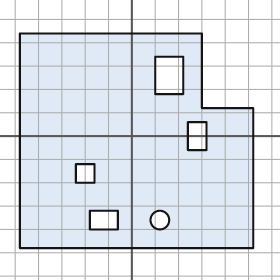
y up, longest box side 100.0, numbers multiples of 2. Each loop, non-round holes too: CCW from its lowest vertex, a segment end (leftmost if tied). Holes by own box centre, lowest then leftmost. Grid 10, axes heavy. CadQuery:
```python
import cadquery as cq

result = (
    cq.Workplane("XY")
    .moveTo(-48.0, -48.0)
    .lineTo(52.0, -48.0)
    .lineTo(52.0, 12.0)
    .lineTo(30.0, 12.0)
    .lineTo(30.0, 44.0)
    .lineTo(-48.0, 44.0)
    .close()
    .moveTo(-18.0, -40.0)
    .lineTo(-6.0, -40.0)
    .lineTo(-6.0, -32.0)
    .lineTo(-18.0, -32.0)
    .close()
    .moveTo(12.0, -36.0)
    .circle(4.0)
    .moveTo(-24.0, -20.0)
    .lineTo(-16.0, -20.0)
    .lineTo(-16.0, -12.0)
    .lineTo(-24.0, -12.0)
    .close()
    .moveTo(24.0, -6.0)
    .lineTo(32.0, -6.0)
    .lineTo(32.0, 6.0)
    .lineTo(24.0, 6.0)
    .close()
    .moveTo(10.0, 18.0)
    .lineTo(22.0, 18.0)
    .lineTo(22.0, 34.0)
    .lineTo(10.0, 34.0)
    .close()
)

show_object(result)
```